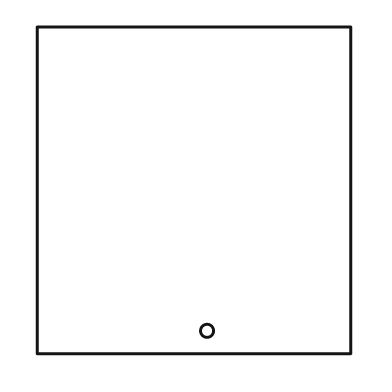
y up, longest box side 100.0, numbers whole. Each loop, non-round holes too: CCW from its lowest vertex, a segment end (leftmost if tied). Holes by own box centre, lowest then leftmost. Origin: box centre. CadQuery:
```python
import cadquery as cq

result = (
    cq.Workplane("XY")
    .moveTo(-48.0, -50.0)
    .lineTo(48.0, -50.0)
    .lineTo(48.0, 50.0)
    .lineTo(-48.0, 50.0)
    .close()
    .moveTo(4.0, -43.0)
    .circle(2.0)
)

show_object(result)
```